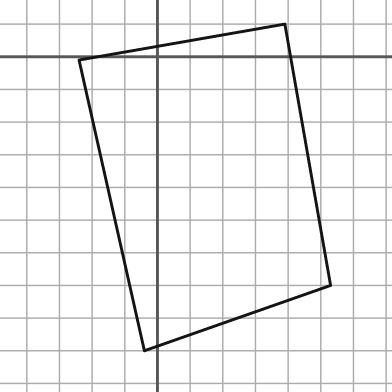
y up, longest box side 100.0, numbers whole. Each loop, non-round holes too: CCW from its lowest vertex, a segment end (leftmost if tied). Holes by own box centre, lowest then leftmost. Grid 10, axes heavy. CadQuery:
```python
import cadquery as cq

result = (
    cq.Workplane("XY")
    .moveTo(-4.0, -90.0)
    .lineTo(53.0, -70.0)
    .lineTo(39.0, 10.0)
    .lineTo(-24.0, -1.0)
    .close()
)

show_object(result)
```